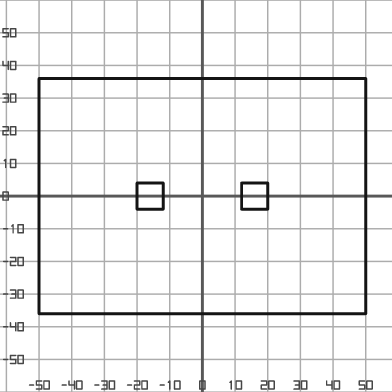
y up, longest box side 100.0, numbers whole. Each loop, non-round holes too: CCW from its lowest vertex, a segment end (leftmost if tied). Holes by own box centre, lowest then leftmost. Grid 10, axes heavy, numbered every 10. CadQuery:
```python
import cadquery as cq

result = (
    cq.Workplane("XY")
    .moveTo(-50.0, -36.0)
    .lineTo(50.0, -36.0)
    .lineTo(50.0, 36.0)
    .lineTo(-50.0, 36.0)
    .close()
    .moveTo(-20.0, -4.0)
    .lineTo(-12.0, -4.0)
    .lineTo(-12.0, 4.0)
    .lineTo(-20.0, 4.0)
    .close()
    .moveTo(12.0, -4.0)
    .lineTo(20.0, -4.0)
    .lineTo(20.0, 4.0)
    .lineTo(12.0, 4.0)
    .close()
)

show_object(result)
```